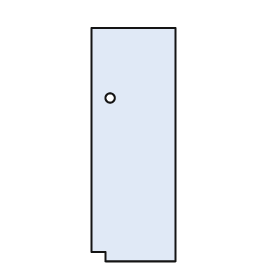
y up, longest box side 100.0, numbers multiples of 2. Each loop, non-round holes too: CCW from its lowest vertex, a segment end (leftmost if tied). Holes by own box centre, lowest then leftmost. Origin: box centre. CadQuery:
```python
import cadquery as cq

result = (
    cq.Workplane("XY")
    .moveTo(-12.0, -50.0)
    .lineTo(18.0, -50.0)
    .lineTo(18.0, 50.0)
    .lineTo(-18.0, 50.0)
    .lineTo(-18.0, -46.0)
    .lineTo(-12.0, -46.0)
    .close()
    .moveTo(-10.0, 20.0)
    .circle(2.0)
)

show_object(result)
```